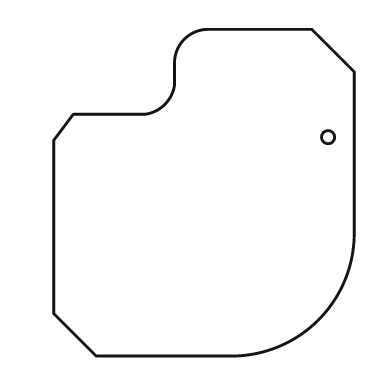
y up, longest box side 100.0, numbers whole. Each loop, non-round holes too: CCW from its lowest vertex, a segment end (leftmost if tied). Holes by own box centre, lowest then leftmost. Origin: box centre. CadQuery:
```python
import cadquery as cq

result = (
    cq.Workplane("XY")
    .moveTo(-33.0, -50.0)
    .lineTo(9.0, -50.0)
    .threePointArc((35.0, -39.0), (46.0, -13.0))
    .lineTo(46.0, 37.0)
    .lineTo(33.0, 50.0)
    .lineTo(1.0, 50.0)
    .threePointArc((-6.0, 47.0), (-9.0, 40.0))
    .lineTo(-9.0, 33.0)
    .threePointArc((-12.0, 27.0), (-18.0, 24.0))
    .lineTo(-40.0, 24.0)
    .lineTo(-46.0, 16.0)
    .lineTo(-46.0, -37.0)
    .close()
    .moveTo(38.0, 17.0)
    .circle(2.0)
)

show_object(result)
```